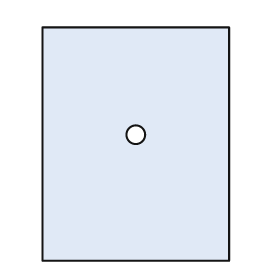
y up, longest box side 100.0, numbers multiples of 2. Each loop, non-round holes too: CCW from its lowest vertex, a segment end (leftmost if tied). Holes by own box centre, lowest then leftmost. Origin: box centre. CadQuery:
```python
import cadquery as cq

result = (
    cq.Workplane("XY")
    .moveTo(-40.0, -50.0)
    .lineTo(40.0, -50.0)
    .lineTo(40.0, 50.0)
    .lineTo(-40.0, 50.0)
    .close()
    .moveTo(0.0, 4.0)
    .circle(4.0)
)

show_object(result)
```